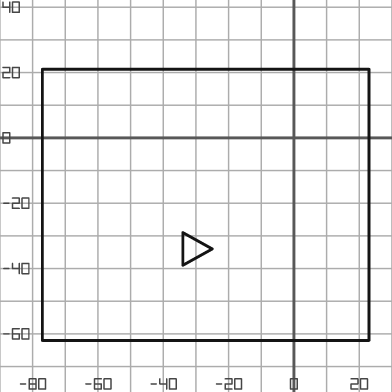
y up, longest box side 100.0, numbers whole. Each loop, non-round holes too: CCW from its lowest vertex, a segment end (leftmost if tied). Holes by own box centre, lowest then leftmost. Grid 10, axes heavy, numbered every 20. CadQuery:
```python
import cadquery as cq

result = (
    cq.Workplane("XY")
    .moveTo(-77.0, -62.0)
    .lineTo(23.0, -62.0)
    .lineTo(23.0, 21.0)
    .lineTo(-77.0, 21.0)
    .close()
    .moveTo(-34.0, -39.0)
    .lineTo(-25.0, -34.0)
    .lineTo(-34.0, -29.0)
    .close()
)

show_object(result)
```